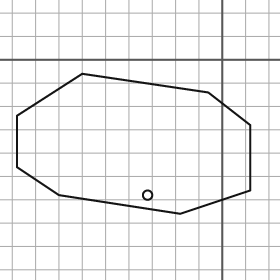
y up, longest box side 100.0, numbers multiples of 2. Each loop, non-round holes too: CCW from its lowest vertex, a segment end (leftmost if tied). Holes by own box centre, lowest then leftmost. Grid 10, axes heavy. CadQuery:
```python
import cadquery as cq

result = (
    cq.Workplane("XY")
    .moveTo(-18.0, -66.0)
    .lineTo(12.0, -56.0)
    .lineTo(12.0, -28.0)
    .lineTo(-6.0, -14.0)
    .lineTo(-60.0, -6.0)
    .lineTo(-88.0, -24.0)
    .lineTo(-88.0, -46.0)
    .lineTo(-70.0, -58.0)
    .close()
    .moveTo(-32.0, -58.0)
    .circle(2.0)
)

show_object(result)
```